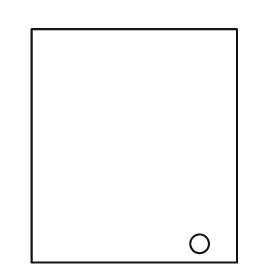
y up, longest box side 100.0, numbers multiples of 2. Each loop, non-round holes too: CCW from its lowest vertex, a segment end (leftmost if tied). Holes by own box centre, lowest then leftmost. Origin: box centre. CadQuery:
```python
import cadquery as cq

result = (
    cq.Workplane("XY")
    .moveTo(-44.0, -50.0)
    .lineTo(44.0, -50.0)
    .lineTo(44.0, 50.0)
    .lineTo(-44.0, 50.0)
    .close()
    .moveTo(28.0, -42.0)
    .circle(4.0)
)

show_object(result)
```